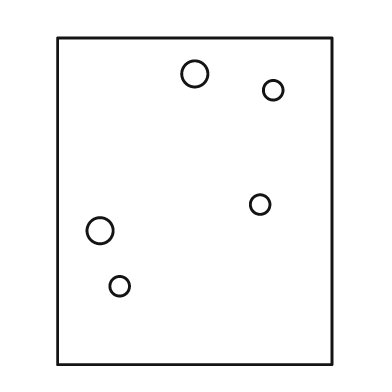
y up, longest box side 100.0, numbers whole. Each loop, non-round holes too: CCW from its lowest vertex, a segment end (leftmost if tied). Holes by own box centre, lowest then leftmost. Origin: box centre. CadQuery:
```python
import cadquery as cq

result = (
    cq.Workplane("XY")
    .moveTo(-42.0, -50.0)
    .lineTo(42.0, -50.0)
    .lineTo(42.0, 50.0)
    .lineTo(-42.0, 50.0)
    .close()
    .moveTo(-23.0, -26.0)
    .circle(3.0)
    .moveTo(-29.0, -9.0)
    .circle(4.0)
    .moveTo(20.0, -1.0)
    .circle(3.0)
    .moveTo(24.0, 34.0)
    .circle(3.0)
    .moveTo(0.0, 39.0)
    .circle(4.0)
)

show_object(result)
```